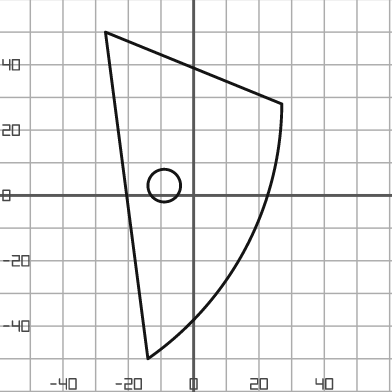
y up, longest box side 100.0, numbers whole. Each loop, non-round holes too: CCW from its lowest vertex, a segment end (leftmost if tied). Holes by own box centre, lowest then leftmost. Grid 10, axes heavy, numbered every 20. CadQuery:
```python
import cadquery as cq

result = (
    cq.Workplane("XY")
    .moveTo(-14.0, -50.0)
    .threePointArc((16.0, -16.0), (27.0, 28.0))
    .lineTo(-27.0, 50.0)
    .close()
    .moveTo(-9.0, 3.0)
    .circle(5.0)
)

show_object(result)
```